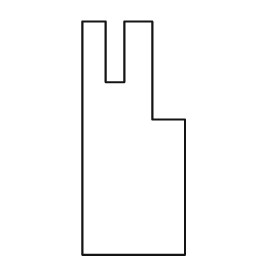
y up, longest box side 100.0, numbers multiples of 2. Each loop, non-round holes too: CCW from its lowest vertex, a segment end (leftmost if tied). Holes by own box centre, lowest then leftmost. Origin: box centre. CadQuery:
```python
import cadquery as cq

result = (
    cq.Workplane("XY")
    .moveTo(-22.0, -50.0)
    .lineTo(22.0, -50.0)
    .lineTo(22.0, 8.0)
    .lineTo(8.0, 8.0)
    .lineTo(8.0, 50.0)
    .lineTo(-4.0, 50.0)
    .lineTo(-4.0, 24.0)
    .lineTo(-12.0, 24.0)
    .lineTo(-12.0, 50.0)
    .lineTo(-22.0, 50.0)
    .close()
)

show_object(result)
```